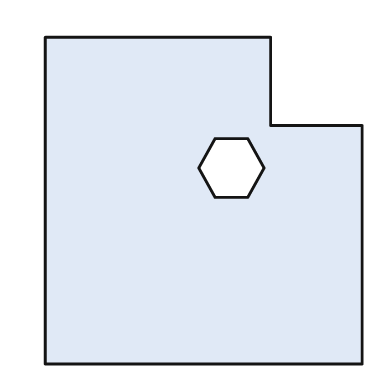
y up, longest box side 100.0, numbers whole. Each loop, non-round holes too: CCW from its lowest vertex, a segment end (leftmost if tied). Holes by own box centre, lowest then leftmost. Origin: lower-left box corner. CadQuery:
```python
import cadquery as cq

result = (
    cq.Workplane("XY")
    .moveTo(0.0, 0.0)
    .lineTo(97.0, 0.0)
    .lineTo(97.0, 73.0)
    .lineTo(69.0, 73.0)
    .lineTo(69.0, 100.0)
    .lineTo(0.0, 100.0)
    .close()
    .moveTo(52.0, 51.0)
    .lineTo(62.0, 51.0)
    .lineTo(67.0, 60.0)
    .lineTo(62.0, 69.0)
    .lineTo(52.0, 69.0)
    .lineTo(47.0, 60.0)
    .close()
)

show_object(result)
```